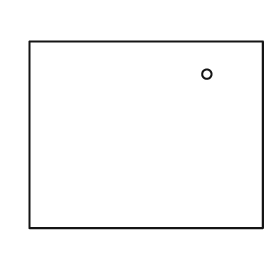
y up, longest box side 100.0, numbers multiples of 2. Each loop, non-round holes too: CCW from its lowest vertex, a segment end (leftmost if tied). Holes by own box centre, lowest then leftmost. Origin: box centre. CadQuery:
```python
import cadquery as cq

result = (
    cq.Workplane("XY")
    .moveTo(-50.0, -40.0)
    .lineTo(50.0, -40.0)
    .lineTo(50.0, 40.0)
    .lineTo(-50.0, 40.0)
    .close()
    .moveTo(26.0, 26.0)
    .circle(2.0)
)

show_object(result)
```